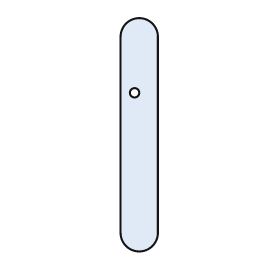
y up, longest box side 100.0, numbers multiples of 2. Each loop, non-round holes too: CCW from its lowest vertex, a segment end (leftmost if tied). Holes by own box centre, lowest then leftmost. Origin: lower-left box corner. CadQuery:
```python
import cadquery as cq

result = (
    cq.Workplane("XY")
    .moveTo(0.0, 8.0)
    .threePointArc((8.0, 0.0), (16.0, 8.0))
    .lineTo(16.0, 92.0)
    .threePointArc((8.0, 100.0), (0.0, 92.0))
    .close()
    .moveTo(6.0, 68.0)
    .circle(2.0)
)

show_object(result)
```